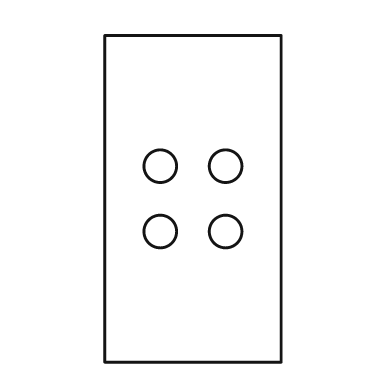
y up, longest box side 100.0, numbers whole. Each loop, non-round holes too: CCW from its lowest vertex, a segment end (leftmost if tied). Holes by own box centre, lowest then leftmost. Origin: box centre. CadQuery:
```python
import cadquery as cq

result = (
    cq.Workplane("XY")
    .moveTo(-27.0, -50.0)
    .lineTo(27.0, -50.0)
    .lineTo(27.0, 50.0)
    .lineTo(-27.0, 50.0)
    .close()
    .moveTo(-10.0, -10.0)
    .circle(5.0)
    .moveTo(10.0, -10.0)
    .circle(5.0)
    .moveTo(-10.0, 10.0)
    .circle(5.0)
    .moveTo(10.0, 10.0)
    .circle(5.0)
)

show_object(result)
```